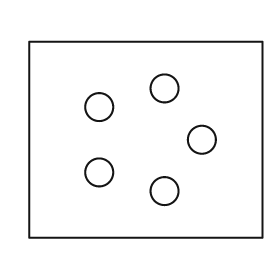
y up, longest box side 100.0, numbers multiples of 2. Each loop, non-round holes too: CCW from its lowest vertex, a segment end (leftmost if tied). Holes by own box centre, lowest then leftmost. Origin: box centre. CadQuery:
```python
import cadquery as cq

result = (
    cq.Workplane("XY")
    .moveTo(-50.0, -42.0)
    .lineTo(50.0, -42.0)
    .lineTo(50.0, 42.0)
    .lineTo(-50.0, 42.0)
    .close()
    .moveTo(8.0, -22.0)
    .circle(6.0)
    .moveTo(-20.0, -14.0)
    .circle(6.0)
    .moveTo(24.0, 0.0)
    .circle(6.0)
    .moveTo(-20.0, 14.0)
    .circle(6.0)
    .moveTo(8.0, 22.0)
    .circle(6.0)
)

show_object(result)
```